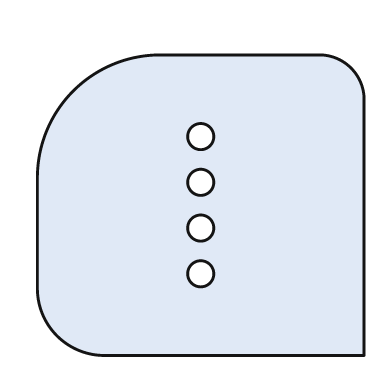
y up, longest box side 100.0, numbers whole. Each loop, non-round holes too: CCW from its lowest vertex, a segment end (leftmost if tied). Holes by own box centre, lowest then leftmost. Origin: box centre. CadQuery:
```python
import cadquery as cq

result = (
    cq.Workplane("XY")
    .moveTo(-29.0, -46.0)
    .lineTo(50.0, -46.0)
    .lineTo(50.0, 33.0)
    .threePointArc((46.0, 42.0), (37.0, 46.0))
    .lineTo(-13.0, 46.0)
    .threePointArc((-39.0, 35.0), (-50.0, 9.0))
    .lineTo(-50.0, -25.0)
    .threePointArc((-44.0, -40.0), (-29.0, -46.0))
    .close()
    .moveTo(0.0, -21.0)
    .circle(4.0)
    .moveTo(0.0, -7.0)
    .circle(4.0)
    .moveTo(0.0, 7.0)
    .circle(4.0)
    .moveTo(0.0, 21.0)
    .circle(4.0)
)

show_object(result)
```